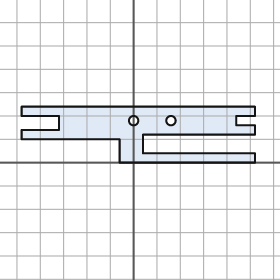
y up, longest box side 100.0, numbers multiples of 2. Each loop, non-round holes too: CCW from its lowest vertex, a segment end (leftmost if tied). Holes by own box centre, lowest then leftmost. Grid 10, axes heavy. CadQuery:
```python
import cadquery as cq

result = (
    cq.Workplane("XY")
    .moveTo(-6.0, 0.0)
    .lineTo(52.0, 0.0)
    .lineTo(52.0, 4.0)
    .lineTo(4.0, 4.0)
    .lineTo(4.0, 12.0)
    .lineTo(52.0, 12.0)
    .lineTo(52.0, 16.0)
    .lineTo(44.0, 16.0)
    .lineTo(44.0, 20.0)
    .lineTo(52.0, 20.0)
    .lineTo(52.0, 24.0)
    .lineTo(-48.0, 24.0)
    .lineTo(-48.0, 20.0)
    .lineTo(-32.0, 20.0)
    .lineTo(-32.0, 14.0)
    .lineTo(-48.0, 14.0)
    .lineTo(-48.0, 10.0)
    .lineTo(-6.0, 10.0)
    .close()
    .moveTo(0.0, 18.0)
    .circle(2.0)
    .moveTo(16.0, 18.0)
    .circle(2.0)
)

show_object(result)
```